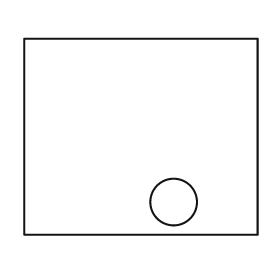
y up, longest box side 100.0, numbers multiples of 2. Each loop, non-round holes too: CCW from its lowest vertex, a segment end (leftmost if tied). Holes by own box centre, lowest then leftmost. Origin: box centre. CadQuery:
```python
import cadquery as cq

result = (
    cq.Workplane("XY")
    .moveTo(-50.0, -42.0)
    .lineTo(50.0, -42.0)
    .lineTo(50.0, 42.0)
    .lineTo(-50.0, 42.0)
    .close()
    .moveTo(14.0, -28.0)
    .circle(10.0)
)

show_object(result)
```